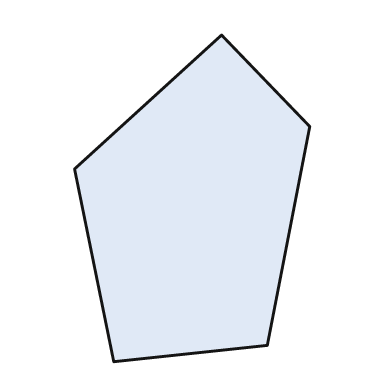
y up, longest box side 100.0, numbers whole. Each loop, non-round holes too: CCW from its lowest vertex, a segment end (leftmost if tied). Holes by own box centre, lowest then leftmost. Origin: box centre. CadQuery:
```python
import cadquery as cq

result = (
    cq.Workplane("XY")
    .moveTo(-24.0, -50.0)
    .lineTo(23.0, -45.0)
    .lineTo(36.0, 22.0)
    .lineTo(9.0, 50.0)
    .lineTo(-36.0, 9.0)
    .close()
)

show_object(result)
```